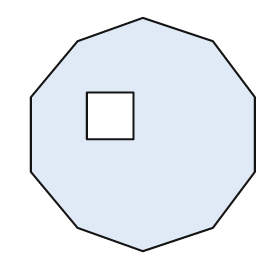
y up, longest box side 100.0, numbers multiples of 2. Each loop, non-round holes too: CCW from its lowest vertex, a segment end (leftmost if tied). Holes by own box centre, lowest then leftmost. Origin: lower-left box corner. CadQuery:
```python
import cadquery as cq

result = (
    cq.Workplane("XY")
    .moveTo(48.0, 0.0)
    .lineTo(78.0, 10.0)
    .lineTo(96.0, 34.0)
    .lineTo(96.0, 66.0)
    .lineTo(78.0, 90.0)
    .lineTo(48.0, 100.0)
    .lineTo(20.0, 90.0)
    .lineTo(0.0, 66.0)
    .lineTo(0.0, 34.0)
    .lineTo(20.0, 10.0)
    .close()
    .moveTo(24.0, 48.0)
    .lineTo(44.0, 48.0)
    .lineTo(44.0, 68.0)
    .lineTo(24.0, 68.0)
    .close()
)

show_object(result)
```